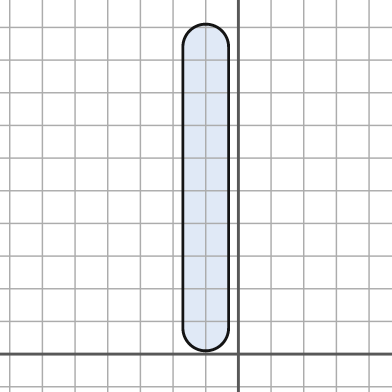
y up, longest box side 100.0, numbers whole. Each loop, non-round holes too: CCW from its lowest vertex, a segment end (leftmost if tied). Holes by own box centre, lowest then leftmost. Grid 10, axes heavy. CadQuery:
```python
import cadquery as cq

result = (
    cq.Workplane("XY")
    .moveTo(-17.0, 8.0)
    .threePointArc((-10.0, 1.0), (-3.0, 8.0))
    .lineTo(-3.0, 94.0)
    .threePointArc((-10.0, 101.0), (-17.0, 94.0))
    .close()
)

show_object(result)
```